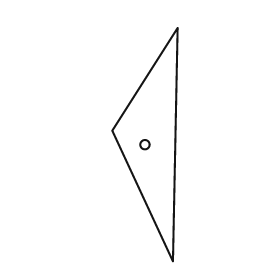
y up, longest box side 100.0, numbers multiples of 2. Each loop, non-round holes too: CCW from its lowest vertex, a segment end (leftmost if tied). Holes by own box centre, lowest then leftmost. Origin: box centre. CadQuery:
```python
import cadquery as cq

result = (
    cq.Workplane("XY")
    .moveTo(12.0, -50.0)
    .lineTo(14.0, 50.0)
    .lineTo(-14.0, 6.0)
    .close()
    .moveTo(0.0, 0.0)
    .circle(2.0)
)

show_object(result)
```